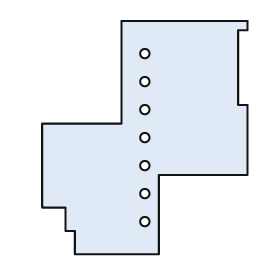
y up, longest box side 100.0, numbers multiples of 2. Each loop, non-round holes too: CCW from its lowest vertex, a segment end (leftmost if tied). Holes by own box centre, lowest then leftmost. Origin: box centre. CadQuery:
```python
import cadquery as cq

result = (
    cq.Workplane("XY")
    .moveTo(-30.0, -50.0)
    .lineTo(6.0, -50.0)
    .lineTo(6.0, -16.0)
    .lineTo(44.0, -16.0)
    .lineTo(44.0, 14.0)
    .lineTo(40.0, 14.0)
    .lineTo(40.0, 46.0)
    .lineTo(44.0, 46.0)
    .lineTo(44.0, 50.0)
    .lineTo(-10.0, 50.0)
    .lineTo(-10.0, 6.0)
    .lineTo(-44.0, 6.0)
    .lineTo(-44.0, -30.0)
    .lineTo(-34.0, -30.0)
    .lineTo(-34.0, -40.0)
    .lineTo(-30.0, -40.0)
    .close()
    .moveTo(0.0, -36.0)
    .circle(2.0)
    .moveTo(0.0, -24.0)
    .circle(2.0)
    .moveTo(0.0, -12.0)
    .circle(2.0)
    .moveTo(0.0, 0.0)
    .circle(2.0)
    .moveTo(0.0, 12.0)
    .circle(2.0)
    .moveTo(0.0, 24.0)
    .circle(2.0)
    .moveTo(0.0, 36.0)
    .circle(2.0)
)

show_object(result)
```